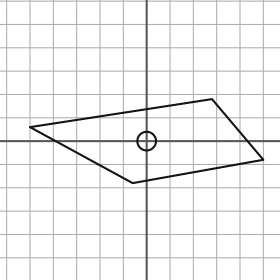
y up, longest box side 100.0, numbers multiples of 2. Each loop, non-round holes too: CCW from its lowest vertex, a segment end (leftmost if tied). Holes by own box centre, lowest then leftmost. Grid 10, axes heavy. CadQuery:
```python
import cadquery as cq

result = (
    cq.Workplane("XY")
    .moveTo(-6.0, -18.0)
    .lineTo(50.0, -8.0)
    .lineTo(28.0, 18.0)
    .lineTo(-50.0, 6.0)
    .close()
    .moveTo(0.0, 0.0)
    .circle(4.0)
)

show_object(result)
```